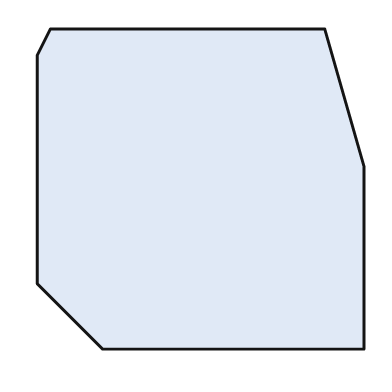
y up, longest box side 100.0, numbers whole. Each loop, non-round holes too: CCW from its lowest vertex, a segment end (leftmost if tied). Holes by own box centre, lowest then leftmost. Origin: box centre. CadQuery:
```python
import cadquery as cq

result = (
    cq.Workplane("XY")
    .moveTo(-30.0, -49.0)
    .lineTo(50.0, -49.0)
    .lineTo(50.0, 7.0)
    .lineTo(38.0, 49.0)
    .lineTo(-46.0, 49.0)
    .lineTo(-50.0, 41.0)
    .lineTo(-50.0, -29.0)
    .close()
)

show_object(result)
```